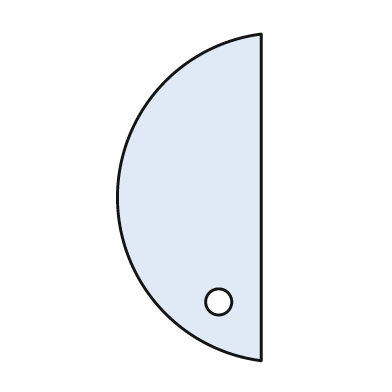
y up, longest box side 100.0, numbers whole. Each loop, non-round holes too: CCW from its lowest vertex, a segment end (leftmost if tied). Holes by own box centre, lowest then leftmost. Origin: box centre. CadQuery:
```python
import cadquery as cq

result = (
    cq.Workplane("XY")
    .moveTo(22.0, -50.0)
    .lineTo(22.0, 50.0)
    .threePointArc((-22.0, 0.0), (22.0, -50.0))
    .close()
    .moveTo(9.0, -32.0)
    .circle(4.0)
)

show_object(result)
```